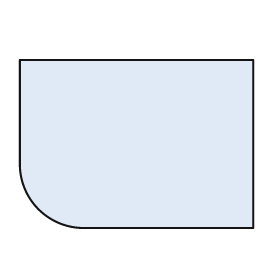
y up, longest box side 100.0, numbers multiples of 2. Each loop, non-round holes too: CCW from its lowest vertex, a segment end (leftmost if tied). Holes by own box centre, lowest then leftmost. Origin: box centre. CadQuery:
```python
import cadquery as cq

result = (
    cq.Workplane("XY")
    .moveTo(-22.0, -36.0)
    .lineTo(50.0, -36.0)
    .lineTo(50.0, 36.0)
    .lineTo(-50.0, 36.0)
    .lineTo(-50.0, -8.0)
    .threePointArc((-42.0, -28.0), (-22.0, -36.0))
    .close()
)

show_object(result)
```